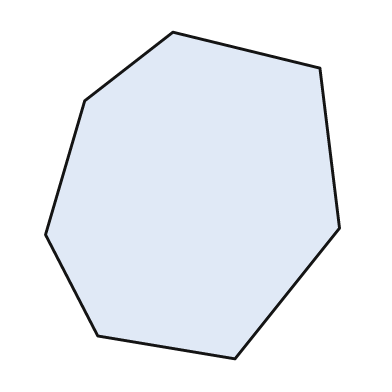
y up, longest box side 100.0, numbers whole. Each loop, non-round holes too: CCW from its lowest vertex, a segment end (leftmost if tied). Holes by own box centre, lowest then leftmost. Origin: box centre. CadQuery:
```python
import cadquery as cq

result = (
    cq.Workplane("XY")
    .moveTo(13.0, -50.0)
    .lineTo(45.0, -10.0)
    .lineTo(39.0, 39.0)
    .lineTo(-6.0, 50.0)
    .lineTo(-33.0, 29.0)
    .lineTo(-45.0, -12.0)
    .lineTo(-29.0, -43.0)
    .close()
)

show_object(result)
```